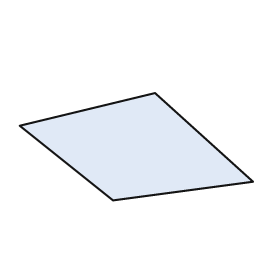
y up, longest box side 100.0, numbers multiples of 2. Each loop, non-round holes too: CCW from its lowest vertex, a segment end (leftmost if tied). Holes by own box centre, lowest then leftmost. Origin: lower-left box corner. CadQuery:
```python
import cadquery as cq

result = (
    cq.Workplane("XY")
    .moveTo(40.0, 0.0)
    .lineTo(100.0, 8.0)
    .lineTo(58.0, 46.0)
    .lineTo(0.0, 32.0)
    .close()
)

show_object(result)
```